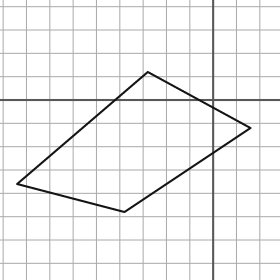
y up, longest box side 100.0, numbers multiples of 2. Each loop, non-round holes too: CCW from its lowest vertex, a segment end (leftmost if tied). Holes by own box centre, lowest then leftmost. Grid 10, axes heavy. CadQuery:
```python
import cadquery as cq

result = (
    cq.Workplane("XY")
    .moveTo(-38.0, -48.0)
    .lineTo(16.0, -12.0)
    .lineTo(-28.0, 12.0)
    .lineTo(-84.0, -36.0)
    .close()
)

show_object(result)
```